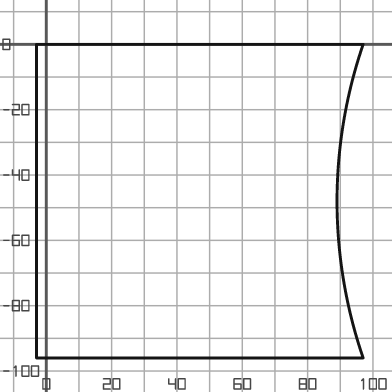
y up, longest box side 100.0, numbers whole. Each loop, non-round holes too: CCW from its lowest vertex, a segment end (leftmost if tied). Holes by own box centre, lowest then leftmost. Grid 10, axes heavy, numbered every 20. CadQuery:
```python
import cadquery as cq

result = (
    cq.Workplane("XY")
    .moveTo(-3.0, -96.0)
    .lineTo(97.0, -96.0)
    .threePointArc((89.0, -48.0), (97.0, 0.0))
    .lineTo(-3.0, 0.0)
    .close()
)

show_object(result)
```